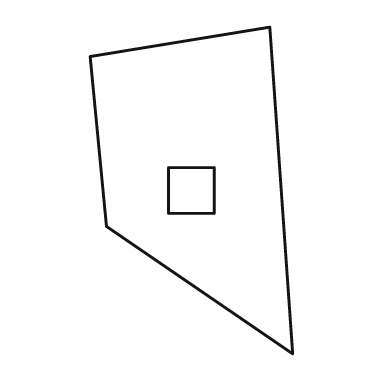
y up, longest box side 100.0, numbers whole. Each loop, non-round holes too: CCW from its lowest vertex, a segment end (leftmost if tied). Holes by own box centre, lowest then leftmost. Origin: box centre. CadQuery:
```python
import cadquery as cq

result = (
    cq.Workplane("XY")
    .moveTo(31.0, -50.0)
    .lineTo(24.0, 50.0)
    .lineTo(-31.0, 41.0)
    .lineTo(-26.0, -11.0)
    .close()
    .moveTo(-7.0, -7.0)
    .lineTo(7.0, -7.0)
    .lineTo(7.0, 7.0)
    .lineTo(-7.0, 7.0)
    .close()
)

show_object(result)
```